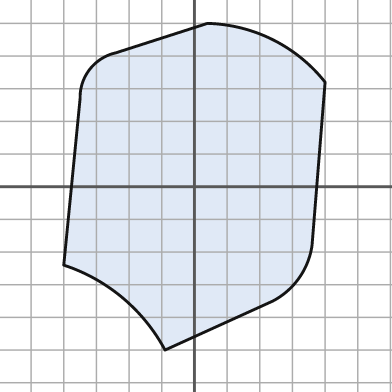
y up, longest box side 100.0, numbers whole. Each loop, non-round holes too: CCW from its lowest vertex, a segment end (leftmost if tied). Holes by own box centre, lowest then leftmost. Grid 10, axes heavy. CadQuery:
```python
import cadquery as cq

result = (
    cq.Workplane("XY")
    .moveTo(-9.0, -50.0)
    .lineTo(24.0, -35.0)
    .threePointArc((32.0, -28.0), (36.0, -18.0))
    .lineTo(40.0, 32.0)
    .threePointArc((24.0, 45.0), (4.0, 50.0))
    .lineTo(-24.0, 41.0)
    .threePointArc((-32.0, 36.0), (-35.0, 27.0))
    .lineTo(-40.0, -24.0)
    .threePointArc((-22.0, -34.0), (-9.0, -50.0))
    .close()
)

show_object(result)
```